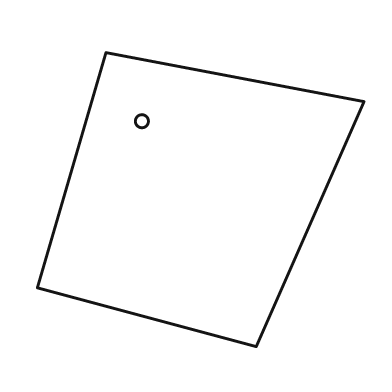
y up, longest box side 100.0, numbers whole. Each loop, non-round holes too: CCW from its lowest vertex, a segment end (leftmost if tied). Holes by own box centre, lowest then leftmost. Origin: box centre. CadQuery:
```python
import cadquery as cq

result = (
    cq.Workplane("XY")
    .moveTo(17.0, -45.0)
    .lineTo(50.0, 30.0)
    .lineTo(-29.0, 45.0)
    .lineTo(-50.0, -27.0)
    .close()
    .moveTo(-18.0, 24.0)
    .circle(2.0)
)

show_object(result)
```